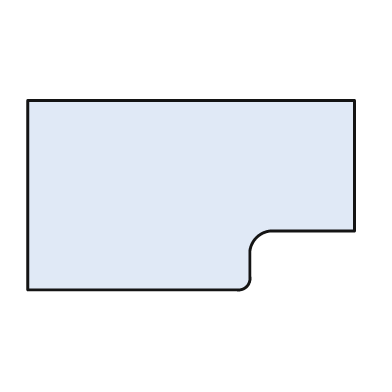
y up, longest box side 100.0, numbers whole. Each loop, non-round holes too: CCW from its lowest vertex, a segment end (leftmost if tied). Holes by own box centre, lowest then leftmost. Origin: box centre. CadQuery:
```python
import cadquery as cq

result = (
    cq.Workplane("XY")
    .moveTo(-50.0, -29.0)
    .lineTo(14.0, -29.0)
    .threePointArc((17.0, -28.0), (18.0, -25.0))
    .lineTo(18.0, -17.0)
    .threePointArc((20.0, -13.0), (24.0, -11.0))
    .lineTo(50.0, -11.0)
    .lineTo(50.0, 29.0)
    .lineTo(-50.0, 29.0)
    .close()
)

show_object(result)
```